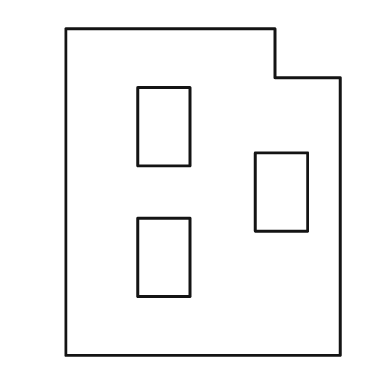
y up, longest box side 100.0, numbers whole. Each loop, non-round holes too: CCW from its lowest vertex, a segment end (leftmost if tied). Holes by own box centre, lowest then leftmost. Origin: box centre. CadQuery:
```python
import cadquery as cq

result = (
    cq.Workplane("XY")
    .moveTo(-42.0, -50.0)
    .lineTo(42.0, -50.0)
    .lineTo(42.0, 35.0)
    .lineTo(22.0, 35.0)
    .lineTo(22.0, 50.0)
    .lineTo(-42.0, 50.0)
    .close()
    .moveTo(-20.0, -32.0)
    .lineTo(-4.0, -32.0)
    .lineTo(-4.0, -8.0)
    .lineTo(-20.0, -8.0)
    .close()
    .moveTo(16.0, -12.0)
    .lineTo(32.0, -12.0)
    .lineTo(32.0, 12.0)
    .lineTo(16.0, 12.0)
    .close()
    .moveTo(-20.0, 8.0)
    .lineTo(-4.0, 8.0)
    .lineTo(-4.0, 32.0)
    .lineTo(-20.0, 32.0)
    .close()
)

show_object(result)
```